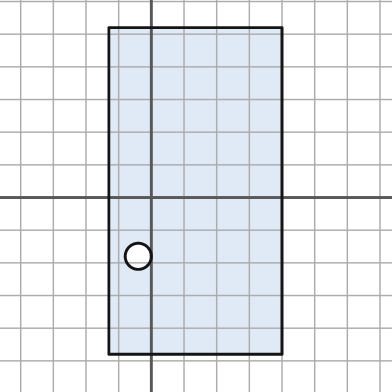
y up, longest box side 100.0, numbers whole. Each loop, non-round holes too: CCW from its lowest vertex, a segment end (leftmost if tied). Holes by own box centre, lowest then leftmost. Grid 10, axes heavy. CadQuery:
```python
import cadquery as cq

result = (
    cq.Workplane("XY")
    .moveTo(-13.0, -48.0)
    .lineTo(40.0, -48.0)
    .lineTo(40.0, 52.0)
    .lineTo(-13.0, 52.0)
    .close()
    .moveTo(-4.0, -18.0)
    .circle(4.0)
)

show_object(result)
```